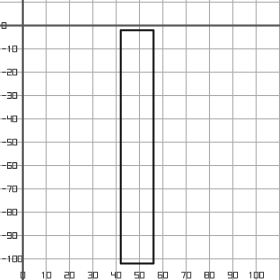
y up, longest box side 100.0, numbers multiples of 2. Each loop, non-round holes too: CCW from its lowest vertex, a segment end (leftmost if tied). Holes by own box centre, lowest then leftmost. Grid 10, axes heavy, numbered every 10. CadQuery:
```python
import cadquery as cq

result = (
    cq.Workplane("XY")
    .moveTo(42.0, -102.0)
    .lineTo(56.0, -102.0)
    .lineTo(56.0, -2.0)
    .lineTo(42.0, -2.0)
    .close()
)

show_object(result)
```